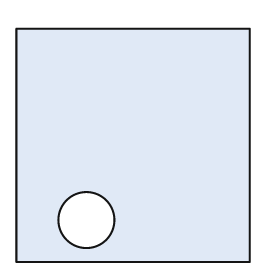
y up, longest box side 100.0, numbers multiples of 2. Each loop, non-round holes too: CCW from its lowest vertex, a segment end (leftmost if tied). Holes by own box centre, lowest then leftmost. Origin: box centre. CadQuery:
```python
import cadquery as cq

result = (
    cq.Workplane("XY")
    .moveTo(-50.0, -50.0)
    .lineTo(50.0, -50.0)
    .lineTo(50.0, 50.0)
    .lineTo(-50.0, 50.0)
    .close()
    .moveTo(-20.0, -32.0)
    .circle(12.0)
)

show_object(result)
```